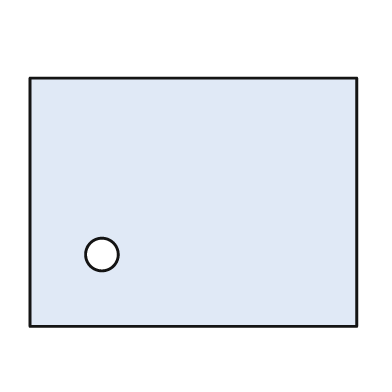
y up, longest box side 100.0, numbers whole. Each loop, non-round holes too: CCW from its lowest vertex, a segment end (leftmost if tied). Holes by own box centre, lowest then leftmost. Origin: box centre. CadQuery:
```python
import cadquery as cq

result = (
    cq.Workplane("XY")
    .moveTo(-50.0, -38.0)
    .lineTo(50.0, -38.0)
    .lineTo(50.0, 38.0)
    .lineTo(-50.0, 38.0)
    .close()
    .moveTo(-28.0, -16.0)
    .circle(5.0)
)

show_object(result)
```